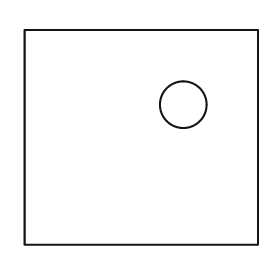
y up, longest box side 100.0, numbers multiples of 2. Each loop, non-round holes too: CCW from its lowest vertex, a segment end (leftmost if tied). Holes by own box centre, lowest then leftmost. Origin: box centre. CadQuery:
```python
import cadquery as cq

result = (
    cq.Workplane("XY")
    .moveTo(-50.0, -46.0)
    .lineTo(50.0, -46.0)
    .lineTo(50.0, 46.0)
    .lineTo(-50.0, 46.0)
    .close()
    .moveTo(18.0, 14.0)
    .circle(10.0)
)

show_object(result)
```